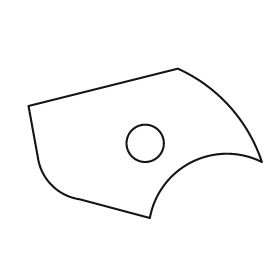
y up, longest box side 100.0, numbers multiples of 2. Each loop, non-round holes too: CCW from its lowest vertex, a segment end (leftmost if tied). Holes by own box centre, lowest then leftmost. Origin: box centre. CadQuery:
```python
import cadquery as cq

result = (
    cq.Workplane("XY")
    .moveTo(2.0, -32.0)
    .threePointArc((20.0, -8.0), (50.0, -8.0))
    .threePointArc((36.0, 16.0), (14.0, 32.0))
    .lineTo(-50.0, 16.0)
    .lineTo(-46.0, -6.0)
    .threePointArc((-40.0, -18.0), (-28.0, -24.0))
    .close()
    .moveTo(0.0, 0.0)
    .circle(8.0)
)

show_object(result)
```